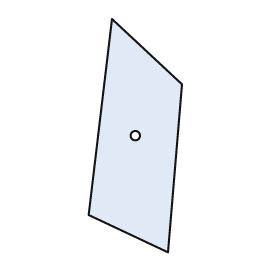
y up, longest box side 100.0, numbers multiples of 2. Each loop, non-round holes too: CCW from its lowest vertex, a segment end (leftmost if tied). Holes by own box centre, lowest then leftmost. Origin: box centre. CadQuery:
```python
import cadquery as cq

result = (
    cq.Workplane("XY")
    .moveTo(14.0, -50.0)
    .lineTo(20.0, 22.0)
    .lineTo(-10.0, 50.0)
    .lineTo(-20.0, -34.0)
    .close()
    .moveTo(0.0, 0.0)
    .circle(2.0)
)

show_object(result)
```